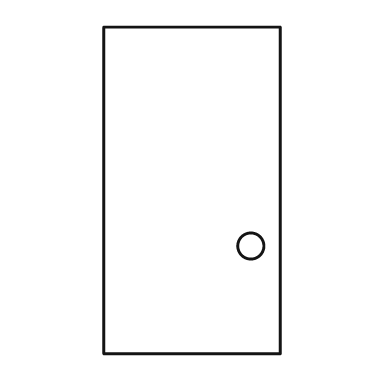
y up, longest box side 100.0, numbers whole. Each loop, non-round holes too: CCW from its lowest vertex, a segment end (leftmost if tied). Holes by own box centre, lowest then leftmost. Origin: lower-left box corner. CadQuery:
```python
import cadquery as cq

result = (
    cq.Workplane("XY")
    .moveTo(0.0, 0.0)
    .lineTo(54.0, 0.0)
    .lineTo(54.0, 100.0)
    .lineTo(0.0, 100.0)
    .close()
    .moveTo(45.0, 33.0)
    .circle(4.0)
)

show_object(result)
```